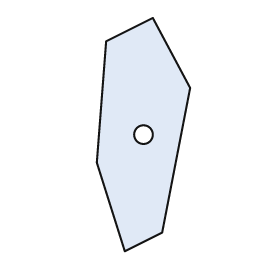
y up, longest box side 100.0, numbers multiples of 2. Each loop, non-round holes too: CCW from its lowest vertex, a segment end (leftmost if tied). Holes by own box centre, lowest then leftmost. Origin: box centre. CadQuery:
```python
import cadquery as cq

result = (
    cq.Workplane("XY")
    .moveTo(-8.0, -50.0)
    .lineTo(8.0, -42.0)
    .lineTo(20.0, 20.0)
    .lineTo(4.0, 50.0)
    .lineTo(-16.0, 40.0)
    .lineTo(-20.0, -12.0)
    .close()
    .moveTo(0.0, 0.0)
    .circle(4.0)
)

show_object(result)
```